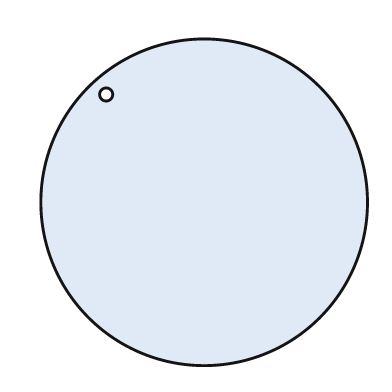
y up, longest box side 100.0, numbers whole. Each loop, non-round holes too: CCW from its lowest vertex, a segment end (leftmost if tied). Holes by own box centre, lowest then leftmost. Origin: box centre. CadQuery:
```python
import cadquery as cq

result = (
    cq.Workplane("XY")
    .moveTo(0.0, 0.0)
    .circle(50.0)
    .moveTo(-30.0, 33.0)
    .circle(2.0)
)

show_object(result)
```